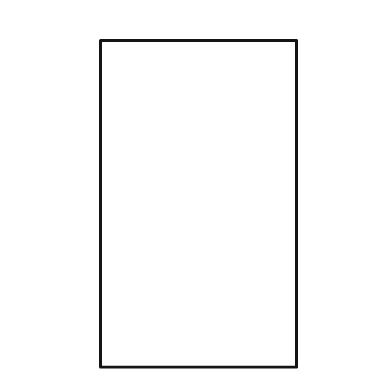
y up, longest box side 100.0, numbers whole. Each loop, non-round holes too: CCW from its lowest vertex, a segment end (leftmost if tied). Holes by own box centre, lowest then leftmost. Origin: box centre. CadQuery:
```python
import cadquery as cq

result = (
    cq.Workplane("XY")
    .moveTo(-30.0, -50.0)
    .lineTo(30.0, -50.0)
    .lineTo(30.0, 50.0)
    .lineTo(-30.0, 50.0)
    .close()
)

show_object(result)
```